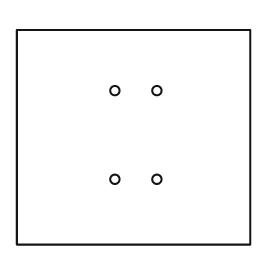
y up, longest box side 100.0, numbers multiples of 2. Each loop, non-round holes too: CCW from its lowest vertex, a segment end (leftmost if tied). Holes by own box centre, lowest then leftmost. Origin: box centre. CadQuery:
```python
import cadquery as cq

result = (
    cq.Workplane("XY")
    .moveTo(-50.0, -46.0)
    .lineTo(50.0, -46.0)
    .lineTo(50.0, 46.0)
    .lineTo(-50.0, 46.0)
    .close()
    .moveTo(-8.0, -18.0)
    .circle(2.0)
    .moveTo(10.0, -18.0)
    .circle(2.0)
    .moveTo(-8.0, 20.0)
    .circle(2.0)
    .moveTo(10.0, 20.0)
    .circle(2.0)
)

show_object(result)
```